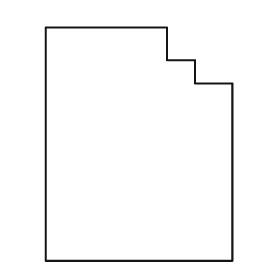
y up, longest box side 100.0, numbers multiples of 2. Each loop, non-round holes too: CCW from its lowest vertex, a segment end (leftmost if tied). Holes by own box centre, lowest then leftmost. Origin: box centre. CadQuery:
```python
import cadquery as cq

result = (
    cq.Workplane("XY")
    .moveTo(-40.0, -50.0)
    .lineTo(40.0, -50.0)
    .lineTo(40.0, 26.0)
    .lineTo(24.0, 26.0)
    .lineTo(24.0, 36.0)
    .lineTo(12.0, 36.0)
    .lineTo(12.0, 50.0)
    .lineTo(-40.0, 50.0)
    .close()
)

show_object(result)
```